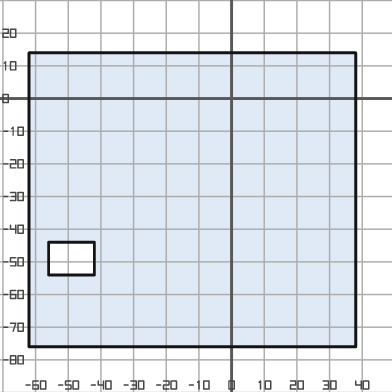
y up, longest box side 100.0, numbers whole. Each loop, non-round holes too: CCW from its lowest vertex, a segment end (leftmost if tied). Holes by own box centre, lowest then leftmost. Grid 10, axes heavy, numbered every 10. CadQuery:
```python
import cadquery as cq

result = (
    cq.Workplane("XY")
    .moveTo(-62.0, -76.0)
    .lineTo(38.0, -76.0)
    .lineTo(38.0, 14.0)
    .lineTo(-62.0, 14.0)
    .close()
    .moveTo(-56.0, -54.0)
    .lineTo(-42.0, -54.0)
    .lineTo(-42.0, -44.0)
    .lineTo(-56.0, -44.0)
    .close()
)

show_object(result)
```